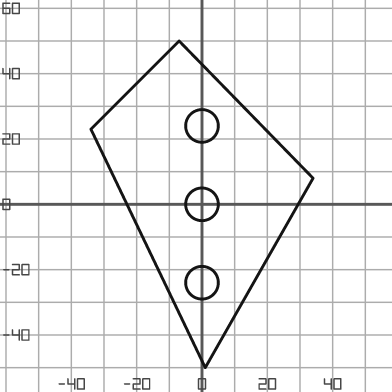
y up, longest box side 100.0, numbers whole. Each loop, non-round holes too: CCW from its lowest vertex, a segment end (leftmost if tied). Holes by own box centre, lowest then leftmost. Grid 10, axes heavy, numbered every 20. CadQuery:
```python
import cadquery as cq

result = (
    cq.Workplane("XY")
    .moveTo(1.0, -50.0)
    .lineTo(34.0, 8.0)
    .lineTo(-7.0, 50.0)
    .lineTo(-34.0, 23.0)
    .close()
    .moveTo(0.0, -24.0)
    .circle(5.0)
    .moveTo(0.0, 0.0)
    .circle(5.0)
    .moveTo(0.0, 24.0)
    .circle(5.0)
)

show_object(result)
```